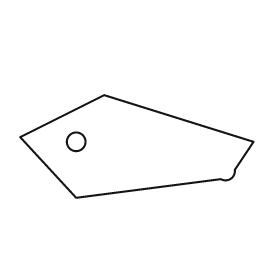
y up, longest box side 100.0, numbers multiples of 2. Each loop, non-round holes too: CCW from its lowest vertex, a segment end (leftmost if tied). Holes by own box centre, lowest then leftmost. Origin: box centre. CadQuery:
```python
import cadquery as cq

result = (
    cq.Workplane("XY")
    .moveTo(-26.0, -22.0)
    .lineTo(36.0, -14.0)
    .threePointArc((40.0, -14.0), (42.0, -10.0))
    .lineTo(50.0, 2.0)
    .lineTo(-14.0, 22.0)
    .lineTo(-50.0, 4.0)
    .close()
    .moveTo(-26.0, 2.0)
    .circle(4.0)
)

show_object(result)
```